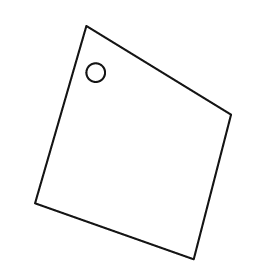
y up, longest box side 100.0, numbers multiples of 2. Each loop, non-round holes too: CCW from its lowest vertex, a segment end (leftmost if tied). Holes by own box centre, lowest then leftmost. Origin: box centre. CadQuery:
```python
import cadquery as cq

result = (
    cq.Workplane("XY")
    .moveTo(26.0, -50.0)
    .lineTo(42.0, 12.0)
    .lineTo(-20.0, 50.0)
    .lineTo(-42.0, -26.0)
    .close()
    .moveTo(-16.0, 30.0)
    .circle(4.0)
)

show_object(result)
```